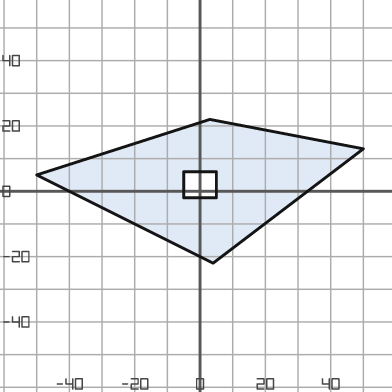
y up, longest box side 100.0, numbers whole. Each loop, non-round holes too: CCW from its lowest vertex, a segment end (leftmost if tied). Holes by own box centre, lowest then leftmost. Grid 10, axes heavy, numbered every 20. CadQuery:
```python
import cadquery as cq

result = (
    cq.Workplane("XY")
    .moveTo(4.0, -22.0)
    .lineTo(50.0, 13.0)
    .lineTo(3.0, 22.0)
    .lineTo(-50.0, 5.0)
    .close()
    .moveTo(-5.0, -2.0)
    .lineTo(5.0, -2.0)
    .lineTo(5.0, 6.0)
    .lineTo(-5.0, 6.0)
    .close()
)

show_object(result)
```